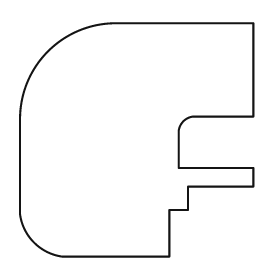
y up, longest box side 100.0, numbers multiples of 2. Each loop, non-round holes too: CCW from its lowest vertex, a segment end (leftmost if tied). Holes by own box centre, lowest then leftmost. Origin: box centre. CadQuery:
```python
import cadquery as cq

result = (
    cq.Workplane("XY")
    .moveTo(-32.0, -50.0)
    .lineTo(14.0, -50.0)
    .lineTo(14.0, -30.0)
    .lineTo(22.0, -30.0)
    .lineTo(22.0, -20.0)
    .lineTo(50.0, -20.0)
    .lineTo(50.0, -12.0)
    .lineTo(18.0, -12.0)
    .lineTo(18.0, 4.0)
    .threePointArc((20.0, 8.0), (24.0, 10.0))
    .lineTo(50.0, 10.0)
    .lineTo(50.0, 50.0)
    .lineTo(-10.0, 50.0)
    .threePointArc((-38.0, 38.0), (-50.0, 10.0))
    .lineTo(-50.0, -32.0)
    .threePointArc((-44.0, -44.0), (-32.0, -50.0))
    .close()
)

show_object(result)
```